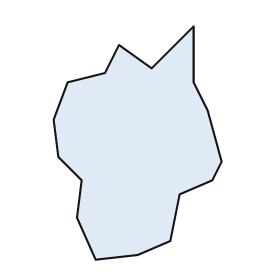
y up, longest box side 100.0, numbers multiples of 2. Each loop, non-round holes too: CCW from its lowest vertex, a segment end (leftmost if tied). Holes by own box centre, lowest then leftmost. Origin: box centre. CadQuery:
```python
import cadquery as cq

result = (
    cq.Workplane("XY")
    .moveTo(-18.0, -50.0)
    .lineTo(0.0, -48.0)
    .lineTo(14.0, -42.0)
    .lineTo(18.0, -22.0)
    .lineTo(32.0, -16.0)
    .lineTo(36.0, -8.0)
    .lineTo(30.0, 14.0)
    .lineTo(24.0, 26.0)
    .lineTo(24.0, 50.0)
    .lineTo(6.0, 32.0)
    .lineTo(-8.0, 42.0)
    .lineTo(-14.0, 30.0)
    .lineTo(-30.0, 26.0)
    .lineTo(-36.0, 10.0)
    .lineTo(-34.0, -6.0)
    .lineTo(-24.0, -16.0)
    .lineTo(-26.0, -32.0)
    .close()
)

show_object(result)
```